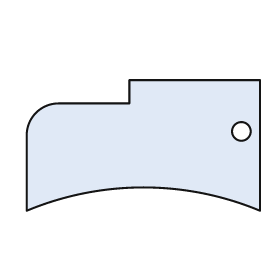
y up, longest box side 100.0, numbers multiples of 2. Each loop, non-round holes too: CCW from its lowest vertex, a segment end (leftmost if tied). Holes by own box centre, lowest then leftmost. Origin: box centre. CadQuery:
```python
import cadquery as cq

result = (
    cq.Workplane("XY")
    .moveTo(-50.0, -28.0)
    .threePointArc((0.0, -18.0), (50.0, -28.0))
    .lineTo(50.0, 28.0)
    .lineTo(-6.0, 28.0)
    .lineTo(-6.0, 18.0)
    .lineTo(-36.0, 18.0)
    .threePointArc((-46.0, 14.0), (-50.0, 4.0))
    .close()
    .moveTo(42.0, 6.0)
    .circle(4.0)
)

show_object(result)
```